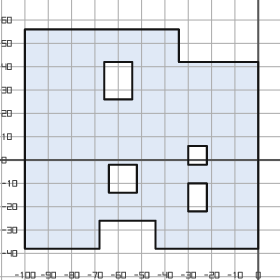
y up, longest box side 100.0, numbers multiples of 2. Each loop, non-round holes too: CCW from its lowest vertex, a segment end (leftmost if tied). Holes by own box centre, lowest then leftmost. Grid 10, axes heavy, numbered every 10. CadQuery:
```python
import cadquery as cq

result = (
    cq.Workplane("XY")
    .moveTo(-100.0, -38.0)
    .lineTo(-68.0, -38.0)
    .lineTo(-68.0, -26.0)
    .lineTo(-44.0, -26.0)
    .lineTo(-44.0, -38.0)
    .lineTo(0.0, -38.0)
    .lineTo(0.0, 42.0)
    .lineTo(-34.0, 42.0)
    .lineTo(-34.0, 56.0)
    .lineTo(-100.0, 56.0)
    .close()
    .moveTo(-30.0, -22.0)
    .lineTo(-22.0, -22.0)
    .lineTo(-22.0, -10.0)
    .lineTo(-30.0, -10.0)
    .close()
    .moveTo(-64.0, -14.0)
    .lineTo(-52.0, -14.0)
    .lineTo(-52.0, -2.0)
    .lineTo(-64.0, -2.0)
    .close()
    .moveTo(-30.0, -2.0)
    .lineTo(-22.0, -2.0)
    .lineTo(-22.0, 6.0)
    .lineTo(-30.0, 6.0)
    .close()
    .moveTo(-66.0, 26.0)
    .lineTo(-54.0, 26.0)
    .lineTo(-54.0, 42.0)
    .lineTo(-66.0, 42.0)
    .close()
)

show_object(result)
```